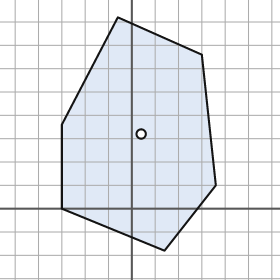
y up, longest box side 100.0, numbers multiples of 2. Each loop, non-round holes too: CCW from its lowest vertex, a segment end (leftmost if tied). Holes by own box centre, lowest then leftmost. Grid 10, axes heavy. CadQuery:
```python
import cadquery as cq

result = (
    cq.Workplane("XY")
    .moveTo(14.0, -18.0)
    .lineTo(36.0, 10.0)
    .lineTo(30.0, 66.0)
    .lineTo(-6.0, 82.0)
    .lineTo(-30.0, 36.0)
    .lineTo(-30.0, 0.0)
    .close()
    .moveTo(4.0, 32.0)
    .circle(2.0)
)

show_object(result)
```